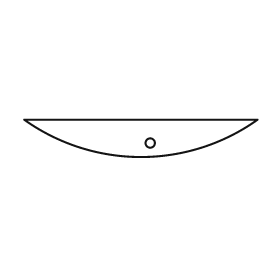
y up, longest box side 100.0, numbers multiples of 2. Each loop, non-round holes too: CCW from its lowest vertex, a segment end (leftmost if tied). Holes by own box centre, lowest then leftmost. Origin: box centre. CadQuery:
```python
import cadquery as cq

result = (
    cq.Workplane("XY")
    .moveTo(-50.0, 8.0)
    .threePointArc((0.0, -8.0), (50.0, 8.0))
    .close()
    .moveTo(4.0, -2.0)
    .circle(2.0)
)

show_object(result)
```